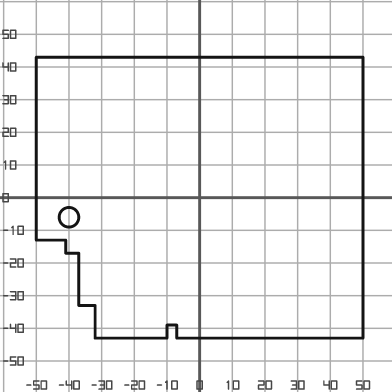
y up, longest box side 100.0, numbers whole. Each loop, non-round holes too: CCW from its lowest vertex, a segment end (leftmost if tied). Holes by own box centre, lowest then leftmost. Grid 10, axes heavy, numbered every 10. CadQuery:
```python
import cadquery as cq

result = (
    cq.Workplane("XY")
    .moveTo(-32.0, -43.0)
    .lineTo(-10.0, -43.0)
    .lineTo(-10.0, -39.0)
    .lineTo(-7.0, -39.0)
    .lineTo(-7.0, -43.0)
    .lineTo(50.0, -43.0)
    .lineTo(50.0, 43.0)
    .lineTo(-50.0, 43.0)
    .lineTo(-50.0, -13.0)
    .lineTo(-41.0, -13.0)
    .lineTo(-41.0, -17.0)
    .lineTo(-37.0, -17.0)
    .lineTo(-37.0, -33.0)
    .lineTo(-32.0, -33.0)
    .close()
    .moveTo(-40.0, -6.0)
    .circle(3.0)
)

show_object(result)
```